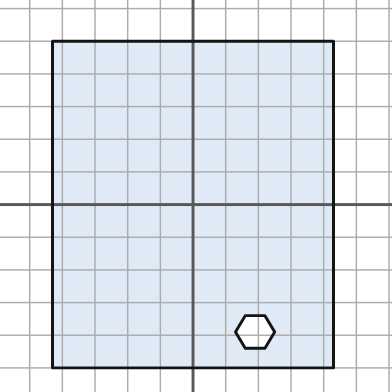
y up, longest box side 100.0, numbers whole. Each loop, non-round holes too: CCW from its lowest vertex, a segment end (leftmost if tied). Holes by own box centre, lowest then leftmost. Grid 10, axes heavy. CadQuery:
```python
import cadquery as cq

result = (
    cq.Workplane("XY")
    .moveTo(-43.0, -50.0)
    .lineTo(43.0, -50.0)
    .lineTo(43.0, 50.0)
    .lineTo(-43.0, 50.0)
    .close()
    .moveTo(16.0, -44.0)
    .lineTo(22.0, -44.0)
    .lineTo(25.0, -39.0)
    .lineTo(22.0, -34.0)
    .lineTo(16.0, -34.0)
    .lineTo(13.0, -39.0)
    .close()
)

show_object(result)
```